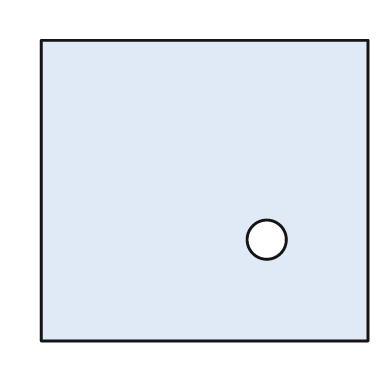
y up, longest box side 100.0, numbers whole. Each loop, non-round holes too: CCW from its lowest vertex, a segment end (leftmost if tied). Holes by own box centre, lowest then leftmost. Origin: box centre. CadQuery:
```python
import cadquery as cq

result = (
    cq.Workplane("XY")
    .moveTo(-50.0, -46.0)
    .lineTo(50.0, -46.0)
    .lineTo(50.0, 46.0)
    .lineTo(-50.0, 46.0)
    .close()
    .moveTo(19.0, -15.0)
    .circle(6.0)
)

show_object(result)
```